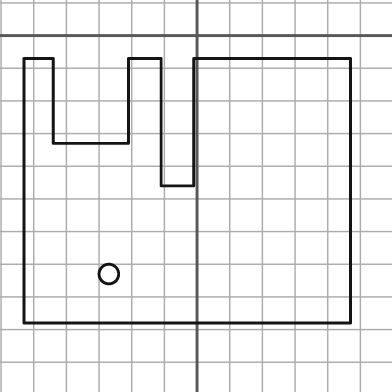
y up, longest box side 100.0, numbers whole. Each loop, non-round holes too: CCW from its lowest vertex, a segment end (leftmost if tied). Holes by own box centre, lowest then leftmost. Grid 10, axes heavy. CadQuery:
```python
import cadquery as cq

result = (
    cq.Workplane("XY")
    .moveTo(-53.0, -88.0)
    .lineTo(47.0, -88.0)
    .lineTo(47.0, -7.0)
    .lineTo(-1.0, -7.0)
    .lineTo(-1.0, -46.0)
    .lineTo(-11.0, -46.0)
    .lineTo(-11.0, -7.0)
    .lineTo(-21.0, -7.0)
    .lineTo(-21.0, -33.0)
    .lineTo(-44.0, -33.0)
    .lineTo(-44.0, -7.0)
    .lineTo(-53.0, -7.0)
    .close()
    .moveTo(-27.0, -73.0)
    .circle(3.0)
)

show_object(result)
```